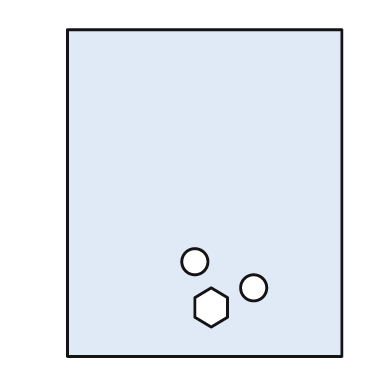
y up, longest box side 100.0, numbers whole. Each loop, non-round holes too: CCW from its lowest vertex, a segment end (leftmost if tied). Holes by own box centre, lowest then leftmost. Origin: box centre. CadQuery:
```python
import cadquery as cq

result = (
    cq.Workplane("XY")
    .moveTo(-42.0, -50.0)
    .lineTo(42.0, -50.0)
    .lineTo(42.0, 50.0)
    .lineTo(-42.0, 50.0)
    .close()
    .moveTo(2.0, -41.0)
    .lineTo(7.0, -38.0)
    .lineTo(7.0, -32.0)
    .lineTo(2.0, -29.0)
    .lineTo(-3.0, -32.0)
    .lineTo(-3.0, -38.0)
    .close()
    .moveTo(15.0, -29.0)
    .circle(4.0)
    .moveTo(-3.0, -21.0)
    .circle(4.0)
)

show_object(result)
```